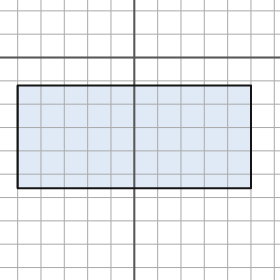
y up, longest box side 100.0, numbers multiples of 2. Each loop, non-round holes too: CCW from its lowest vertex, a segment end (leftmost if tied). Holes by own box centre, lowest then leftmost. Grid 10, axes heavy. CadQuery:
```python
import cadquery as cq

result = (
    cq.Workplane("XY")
    .moveTo(-50.0, -56.0)
    .lineTo(50.0, -56.0)
    .lineTo(50.0, -12.0)
    .lineTo(-50.0, -12.0)
    .close()
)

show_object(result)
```